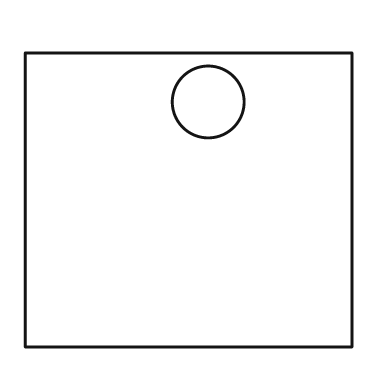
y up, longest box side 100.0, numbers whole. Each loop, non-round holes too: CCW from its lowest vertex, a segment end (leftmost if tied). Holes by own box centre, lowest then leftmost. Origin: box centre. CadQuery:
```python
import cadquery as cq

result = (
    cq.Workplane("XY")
    .moveTo(-50.0, -45.0)
    .lineTo(50.0, -45.0)
    .lineTo(50.0, 45.0)
    .lineTo(-50.0, 45.0)
    .close()
    .moveTo(6.0, 30.0)
    .circle(11.0)
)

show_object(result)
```